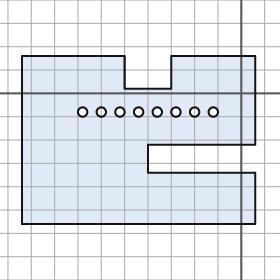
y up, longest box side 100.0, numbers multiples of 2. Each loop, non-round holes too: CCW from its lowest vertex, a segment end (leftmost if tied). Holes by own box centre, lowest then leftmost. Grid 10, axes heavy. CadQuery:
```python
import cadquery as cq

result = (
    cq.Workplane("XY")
    .moveTo(-94.0, -56.0)
    .lineTo(6.0, -56.0)
    .lineTo(6.0, -34.0)
    .lineTo(-40.0, -34.0)
    .lineTo(-40.0, -22.0)
    .lineTo(6.0, -22.0)
    .lineTo(6.0, 16.0)
    .lineTo(-30.0, 16.0)
    .lineTo(-30.0, 2.0)
    .lineTo(-50.0, 2.0)
    .lineTo(-50.0, 16.0)
    .lineTo(-94.0, 16.0)
    .close()
    .moveTo(-68.0, -8.0)
    .circle(2.0)
    .moveTo(-60.0, -8.0)
    .circle(2.0)
    .moveTo(-52.0, -8.0)
    .circle(2.0)
    .moveTo(-44.0, -8.0)
    .circle(2.0)
    .moveTo(-36.0, -8.0)
    .circle(2.0)
    .moveTo(-28.0, -8.0)
    .circle(2.0)
    .moveTo(-20.0, -8.0)
    .circle(2.0)
    .moveTo(-12.0, -8.0)
    .circle(2.0)
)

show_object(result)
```